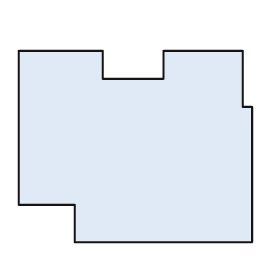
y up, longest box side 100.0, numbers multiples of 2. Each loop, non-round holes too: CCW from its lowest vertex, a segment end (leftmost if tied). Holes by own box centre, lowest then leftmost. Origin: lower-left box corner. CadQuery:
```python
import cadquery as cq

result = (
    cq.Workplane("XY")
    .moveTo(24.0, 0.0)
    .lineTo(100.0, 0.0)
    .lineTo(100.0, 58.0)
    .lineTo(96.0, 58.0)
    .lineTo(96.0, 82.0)
    .lineTo(62.0, 82.0)
    .lineTo(62.0, 70.0)
    .lineTo(36.0, 70.0)
    .lineTo(36.0, 82.0)
    .lineTo(0.0, 82.0)
    .lineTo(0.0, 16.0)
    .lineTo(24.0, 16.0)
    .close()
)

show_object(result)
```